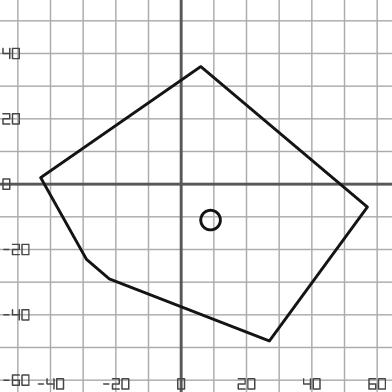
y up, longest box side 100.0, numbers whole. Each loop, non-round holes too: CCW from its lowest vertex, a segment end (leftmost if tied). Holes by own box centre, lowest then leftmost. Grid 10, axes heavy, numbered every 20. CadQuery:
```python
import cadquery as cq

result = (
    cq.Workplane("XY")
    .moveTo(27.0, -48.0)
    .lineTo(57.0, -7.0)
    .lineTo(6.0, 36.0)
    .lineTo(-43.0, 2.0)
    .lineTo(-29.0, -23.0)
    .lineTo(-22.0, -29.0)
    .close()
    .moveTo(9.0, -11.0)
    .circle(3.0)
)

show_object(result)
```